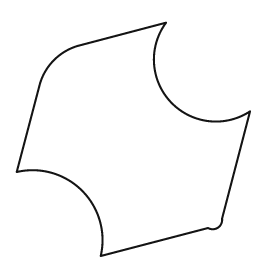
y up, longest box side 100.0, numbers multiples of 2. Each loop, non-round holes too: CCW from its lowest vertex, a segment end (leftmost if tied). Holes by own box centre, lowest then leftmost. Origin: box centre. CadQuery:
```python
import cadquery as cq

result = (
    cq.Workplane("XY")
    .moveTo(-14.0, -50.0)
    .lineTo(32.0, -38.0)
    .threePointArc((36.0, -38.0), (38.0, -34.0))
    .lineTo(50.0, 12.0)
    .threePointArc((16.0, 16.0), (14.0, 50.0))
    .lineTo(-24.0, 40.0)
    .threePointArc((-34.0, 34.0), (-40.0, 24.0))
    .lineTo(-50.0, -14.0)
    .threePointArc((-22.0, -22.0), (-14.0, -50.0))
    .close()
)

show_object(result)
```